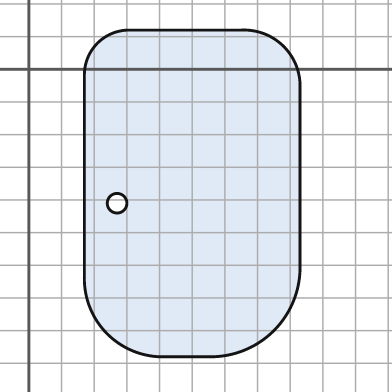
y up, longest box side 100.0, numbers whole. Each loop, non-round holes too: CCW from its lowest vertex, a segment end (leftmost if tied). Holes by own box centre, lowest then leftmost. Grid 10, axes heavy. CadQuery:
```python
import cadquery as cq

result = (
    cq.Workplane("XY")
    .moveTo(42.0, -88.0)
    .lineTo(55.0, -88.0)
    .threePointArc((75.0, -80.0), (83.0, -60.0))
    .lineTo(83.0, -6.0)
    .threePointArc((78.0, 7.0), (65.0, 12.0))
    .lineTo(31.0, 12.0)
    .threePointArc((21.0, 8.0), (17.0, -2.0))
    .lineTo(17.0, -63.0)
    .threePointArc((24.0, -81.0), (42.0, -88.0))
    .close()
    .moveTo(27.0, -41.0)
    .circle(3.0)
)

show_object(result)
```